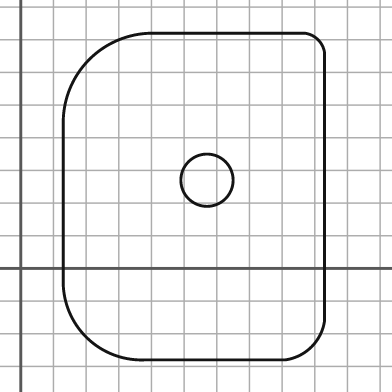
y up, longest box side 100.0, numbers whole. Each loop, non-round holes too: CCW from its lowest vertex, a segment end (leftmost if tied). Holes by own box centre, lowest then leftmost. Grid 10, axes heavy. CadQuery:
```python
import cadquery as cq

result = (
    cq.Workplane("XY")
    .moveTo(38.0, -28.0)
    .lineTo(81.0, -28.0)
    .threePointArc((89.0, -24.0), (93.0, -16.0))
    .lineTo(93.0, 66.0)
    .threePointArc((91.0, 70.0), (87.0, 72.0))
    .lineTo(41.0, 72.0)
    .threePointArc((21.0, 64.0), (13.0, 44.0))
    .lineTo(13.0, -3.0)
    .threePointArc((20.0, -21.0), (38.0, -28.0))
    .close()
    .moveTo(57.0, 27.0)
    .circle(8.0)
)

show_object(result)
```